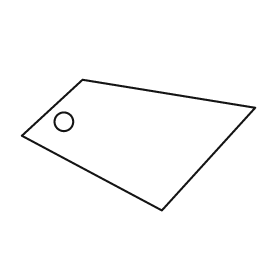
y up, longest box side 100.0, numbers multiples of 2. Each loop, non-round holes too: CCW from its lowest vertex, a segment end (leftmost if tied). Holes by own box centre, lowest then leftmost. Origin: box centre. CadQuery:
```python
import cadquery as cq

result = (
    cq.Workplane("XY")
    .moveTo(10.0, -28.0)
    .lineTo(50.0, 16.0)
    .lineTo(-24.0, 28.0)
    .lineTo(-50.0, 4.0)
    .close()
    .moveTo(-32.0, 10.0)
    .circle(4.0)
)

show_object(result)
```